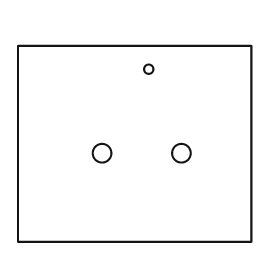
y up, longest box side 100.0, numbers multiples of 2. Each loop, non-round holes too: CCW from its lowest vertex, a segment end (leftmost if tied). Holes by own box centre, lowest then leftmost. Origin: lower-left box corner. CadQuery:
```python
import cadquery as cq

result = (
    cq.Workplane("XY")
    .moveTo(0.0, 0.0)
    .lineTo(100.0, 0.0)
    .lineTo(100.0, 84.0)
    .lineTo(0.0, 84.0)
    .close()
    .moveTo(36.0, 38.0)
    .circle(4.0)
    .moveTo(70.0, 38.0)
    .circle(4.0)
    .moveTo(56.0, 74.0)
    .circle(2.0)
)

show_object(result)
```